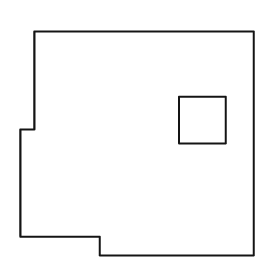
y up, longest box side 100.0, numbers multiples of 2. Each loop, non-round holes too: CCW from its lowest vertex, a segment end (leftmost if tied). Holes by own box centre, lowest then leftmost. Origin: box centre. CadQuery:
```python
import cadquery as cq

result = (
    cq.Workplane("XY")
    .moveTo(-16.0, -48.0)
    .lineTo(50.0, -48.0)
    .lineTo(50.0, 48.0)
    .lineTo(-44.0, 48.0)
    .lineTo(-44.0, 6.0)
    .lineTo(-50.0, 6.0)
    .lineTo(-50.0, -40.0)
    .lineTo(-16.0, -40.0)
    .close()
    .moveTo(18.0, 0.0)
    .lineTo(38.0, 0.0)
    .lineTo(38.0, 20.0)
    .lineTo(18.0, 20.0)
    .close()
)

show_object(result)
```